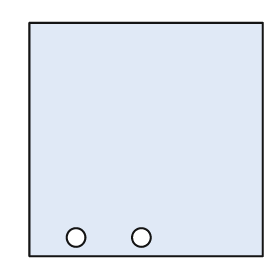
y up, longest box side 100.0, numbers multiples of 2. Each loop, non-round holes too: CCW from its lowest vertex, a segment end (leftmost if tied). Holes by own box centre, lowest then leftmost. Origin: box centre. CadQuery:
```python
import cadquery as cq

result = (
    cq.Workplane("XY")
    .moveTo(-50.0, -50.0)
    .lineTo(50.0, -50.0)
    .lineTo(50.0, 50.0)
    .lineTo(-50.0, 50.0)
    .close()
    .moveTo(-30.0, -42.0)
    .circle(4.0)
    .moveTo(-2.0, -42.0)
    .circle(4.0)
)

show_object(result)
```